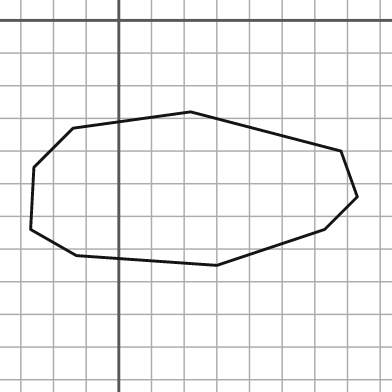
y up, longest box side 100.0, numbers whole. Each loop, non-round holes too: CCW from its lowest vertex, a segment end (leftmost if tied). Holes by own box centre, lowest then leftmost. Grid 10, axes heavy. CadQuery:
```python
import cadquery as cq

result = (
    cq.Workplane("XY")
    .moveTo(30.0, -75.0)
    .lineTo(63.0, -64.0)
    .lineTo(73.0, -54.0)
    .lineTo(68.0, -40.0)
    .lineTo(22.0, -28.0)
    .lineTo(-14.0, -33.0)
    .lineTo(-26.0, -45.0)
    .lineTo(-27.0, -64.0)
    .lineTo(-13.0, -72.0)
    .close()
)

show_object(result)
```